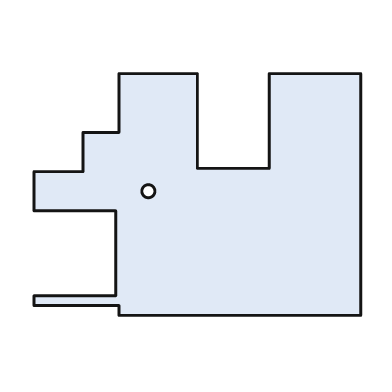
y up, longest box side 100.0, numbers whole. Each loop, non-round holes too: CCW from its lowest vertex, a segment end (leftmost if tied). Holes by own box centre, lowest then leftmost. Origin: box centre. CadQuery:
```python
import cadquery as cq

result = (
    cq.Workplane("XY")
    .moveTo(-24.0, -37.0)
    .lineTo(50.0, -37.0)
    .lineTo(50.0, 37.0)
    .lineTo(22.0, 37.0)
    .lineTo(22.0, 8.0)
    .lineTo(0.0, 8.0)
    .lineTo(0.0, 37.0)
    .lineTo(-24.0, 37.0)
    .lineTo(-24.0, 19.0)
    .lineTo(-35.0, 19.0)
    .lineTo(-35.0, 7.0)
    .lineTo(-50.0, 7.0)
    .lineTo(-50.0, -5.0)
    .lineTo(-25.0, -5.0)
    .lineTo(-25.0, -31.0)
    .lineTo(-50.0, -31.0)
    .lineTo(-50.0, -34.0)
    .lineTo(-24.0, -34.0)
    .close()
    .moveTo(-15.0, 1.0)
    .circle(2.0)
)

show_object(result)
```